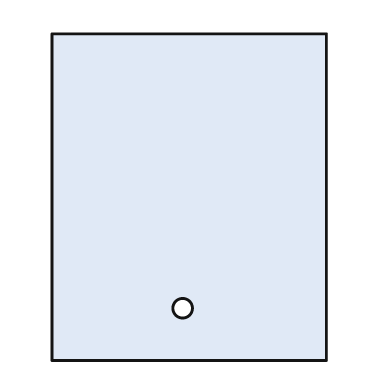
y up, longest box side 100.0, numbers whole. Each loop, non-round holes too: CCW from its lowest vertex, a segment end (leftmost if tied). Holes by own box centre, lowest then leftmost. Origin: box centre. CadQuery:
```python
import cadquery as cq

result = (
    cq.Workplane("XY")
    .moveTo(-42.0, -50.0)
    .lineTo(42.0, -50.0)
    .lineTo(42.0, 50.0)
    .lineTo(-42.0, 50.0)
    .close()
    .moveTo(-2.0, -34.0)
    .circle(3.0)
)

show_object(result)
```